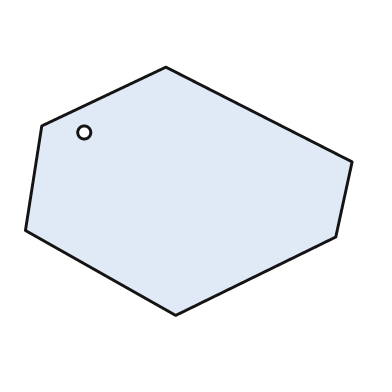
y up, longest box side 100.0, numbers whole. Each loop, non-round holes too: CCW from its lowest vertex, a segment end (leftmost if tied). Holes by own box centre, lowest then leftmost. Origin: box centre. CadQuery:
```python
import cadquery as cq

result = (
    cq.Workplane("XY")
    .moveTo(-4.0, -38.0)
    .lineTo(45.0, -14.0)
    .lineTo(50.0, 9.0)
    .lineTo(-7.0, 38.0)
    .lineTo(-45.0, 20.0)
    .lineTo(-50.0, -12.0)
    .close()
    .moveTo(-32.0, 18.0)
    .circle(2.0)
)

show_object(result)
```